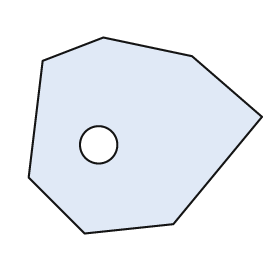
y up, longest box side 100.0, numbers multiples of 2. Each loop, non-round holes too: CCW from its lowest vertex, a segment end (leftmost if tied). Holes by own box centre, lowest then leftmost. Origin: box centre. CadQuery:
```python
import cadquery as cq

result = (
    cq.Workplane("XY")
    .moveTo(-26.0, -42.0)
    .lineTo(12.0, -38.0)
    .lineTo(50.0, 8.0)
    .lineTo(20.0, 34.0)
    .lineTo(-18.0, 42.0)
    .lineTo(-44.0, 32.0)
    .lineTo(-50.0, -18.0)
    .close()
    .moveTo(-20.0, -4.0)
    .circle(8.0)
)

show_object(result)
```